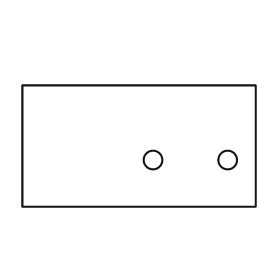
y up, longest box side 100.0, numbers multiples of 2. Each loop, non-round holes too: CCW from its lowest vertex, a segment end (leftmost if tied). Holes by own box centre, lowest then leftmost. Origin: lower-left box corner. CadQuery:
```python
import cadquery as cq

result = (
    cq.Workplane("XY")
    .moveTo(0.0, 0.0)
    .lineTo(100.0, 0.0)
    .lineTo(100.0, 52.0)
    .lineTo(0.0, 52.0)
    .close()
    .moveTo(56.0, 20.0)
    .circle(4.0)
    .moveTo(88.0, 20.0)
    .circle(4.0)
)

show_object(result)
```